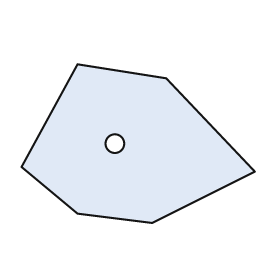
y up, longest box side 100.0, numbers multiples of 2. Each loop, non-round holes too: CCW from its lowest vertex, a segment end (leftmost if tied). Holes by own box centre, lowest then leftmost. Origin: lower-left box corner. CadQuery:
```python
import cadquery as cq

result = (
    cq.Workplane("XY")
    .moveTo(56.0, 0.0)
    .lineTo(100.0, 22.0)
    .lineTo(62.0, 62.0)
    .lineTo(24.0, 68.0)
    .lineTo(0.0, 24.0)
    .lineTo(24.0, 4.0)
    .close()
    .moveTo(40.0, 34.0)
    .circle(4.0)
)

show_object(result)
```